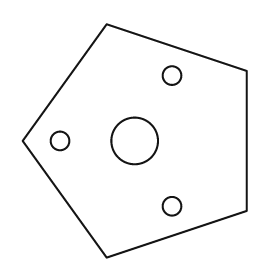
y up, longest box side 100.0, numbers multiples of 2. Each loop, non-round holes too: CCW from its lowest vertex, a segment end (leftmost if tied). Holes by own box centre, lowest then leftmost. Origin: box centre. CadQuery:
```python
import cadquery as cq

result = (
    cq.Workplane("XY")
    .moveTo(-12.0, -50.0)
    .lineTo(48.0, -30.0)
    .lineTo(48.0, 30.0)
    .lineTo(-12.0, 50.0)
    .lineTo(-48.0, 0.0)
    .close()
    .moveTo(16.0, -28.0)
    .circle(4.0)
    .moveTo(-32.0, 0.0)
    .circle(4.0)
    .moveTo(0.0, 0.0)
    .circle(10.0)
    .moveTo(16.0, 28.0)
    .circle(4.0)
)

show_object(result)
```